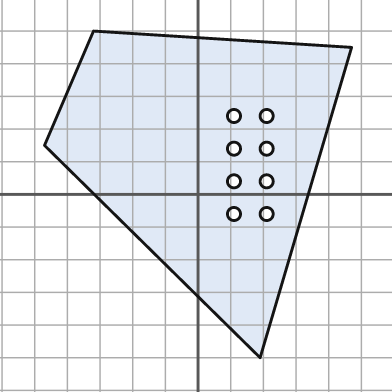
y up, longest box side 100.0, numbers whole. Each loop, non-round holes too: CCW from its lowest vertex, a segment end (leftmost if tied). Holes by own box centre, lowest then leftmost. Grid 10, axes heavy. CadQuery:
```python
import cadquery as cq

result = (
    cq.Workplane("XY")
    .moveTo(19.0, -50.0)
    .lineTo(47.0, 45.0)
    .lineTo(-32.0, 50.0)
    .lineTo(-47.0, 15.0)
    .close()
    .moveTo(11.0, -6.0)
    .circle(2.0)
    .moveTo(21.0, -6.0)
    .circle(2.0)
    .moveTo(11.0, 4.0)
    .circle(2.0)
    .moveTo(21.0, 4.0)
    .circle(2.0)
    .moveTo(11.0, 14.0)
    .circle(2.0)
    .moveTo(21.0, 14.0)
    .circle(2.0)
    .moveTo(11.0, 24.0)
    .circle(2.0)
    .moveTo(21.0, 24.0)
    .circle(2.0)
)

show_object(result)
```